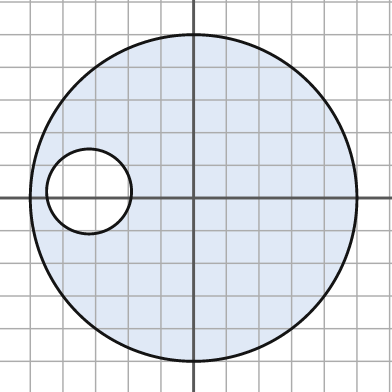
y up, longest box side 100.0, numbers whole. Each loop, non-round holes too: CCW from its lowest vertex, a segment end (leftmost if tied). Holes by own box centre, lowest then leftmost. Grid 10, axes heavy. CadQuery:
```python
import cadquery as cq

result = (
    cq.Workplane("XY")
    .moveTo(0.0, 0.0)
    .circle(50.0)
    .moveTo(-32.0, 2.0)
    .circle(13.0)
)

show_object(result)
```